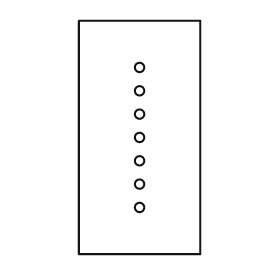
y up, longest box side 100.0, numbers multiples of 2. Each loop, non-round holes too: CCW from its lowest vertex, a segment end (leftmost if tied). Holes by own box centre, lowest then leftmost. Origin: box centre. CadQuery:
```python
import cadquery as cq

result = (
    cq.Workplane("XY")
    .moveTo(-26.0, -50.0)
    .lineTo(26.0, -50.0)
    .lineTo(26.0, 50.0)
    .lineTo(-26.0, 50.0)
    .close()
    .moveTo(0.0, -30.0)
    .circle(2.0)
    .moveTo(0.0, -20.0)
    .circle(2.0)
    .moveTo(0.0, -10.0)
    .circle(2.0)
    .moveTo(0.0, 0.0)
    .circle(2.0)
    .moveTo(0.0, 10.0)
    .circle(2.0)
    .moveTo(0.0, 20.0)
    .circle(2.0)
    .moveTo(0.0, 30.0)
    .circle(2.0)
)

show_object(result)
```